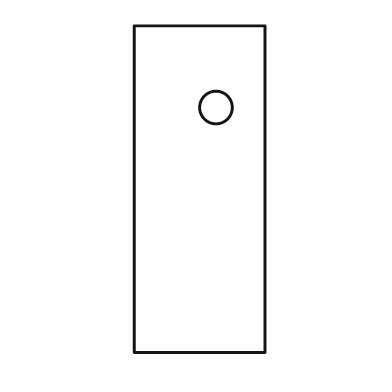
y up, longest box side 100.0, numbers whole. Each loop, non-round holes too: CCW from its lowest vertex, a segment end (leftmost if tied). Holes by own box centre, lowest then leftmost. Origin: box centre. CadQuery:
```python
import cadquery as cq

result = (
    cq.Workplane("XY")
    .moveTo(-20.0, -50.0)
    .lineTo(20.0, -50.0)
    .lineTo(20.0, 50.0)
    .lineTo(-20.0, 50.0)
    .close()
    .moveTo(5.0, 25.0)
    .circle(5.0)
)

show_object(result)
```